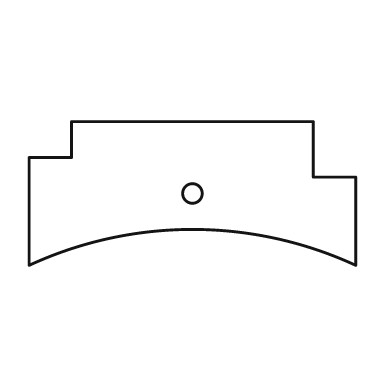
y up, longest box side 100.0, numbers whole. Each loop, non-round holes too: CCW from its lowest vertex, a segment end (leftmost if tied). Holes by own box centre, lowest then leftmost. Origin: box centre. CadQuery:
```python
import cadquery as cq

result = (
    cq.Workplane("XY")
    .moveTo(-50.0, -22.0)
    .threePointArc((0.0, -11.0), (50.0, -22.0))
    .lineTo(50.0, 5.0)
    .lineTo(37.0, 5.0)
    .lineTo(37.0, 22.0)
    .lineTo(-37.0, 22.0)
    .lineTo(-37.0, 11.0)
    .lineTo(-50.0, 11.0)
    .close()
    .moveTo(0.0, 0.0)
    .circle(3.0)
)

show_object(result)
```